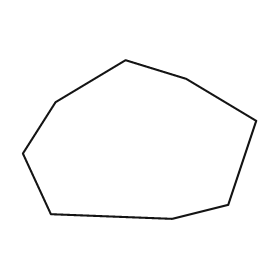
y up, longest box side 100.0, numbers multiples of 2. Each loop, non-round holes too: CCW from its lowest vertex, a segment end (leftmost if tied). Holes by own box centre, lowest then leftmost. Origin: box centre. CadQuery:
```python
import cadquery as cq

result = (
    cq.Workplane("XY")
    .moveTo(14.0, -34.0)
    .lineTo(38.0, -28.0)
    .lineTo(50.0, 8.0)
    .lineTo(20.0, 26.0)
    .lineTo(-6.0, 34.0)
    .lineTo(-36.0, 16.0)
    .lineTo(-50.0, -6.0)
    .lineTo(-38.0, -32.0)
    .close()
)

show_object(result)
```